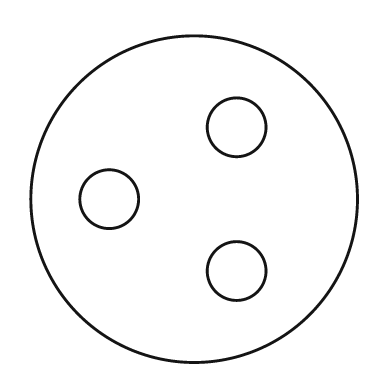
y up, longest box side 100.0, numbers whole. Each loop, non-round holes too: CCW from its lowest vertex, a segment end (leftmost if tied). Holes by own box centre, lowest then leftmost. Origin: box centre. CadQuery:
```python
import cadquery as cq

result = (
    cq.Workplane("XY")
    .moveTo(0.0, 0.0)
    .circle(50.0)
    .moveTo(13.0, -22.0)
    .circle(9.0)
    .moveTo(-26.0, 0.0)
    .circle(9.0)
    .moveTo(13.0, 22.0)
    .circle(9.0)
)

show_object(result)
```